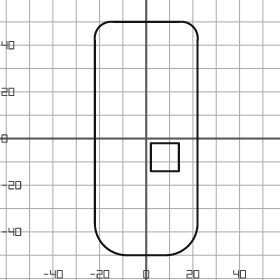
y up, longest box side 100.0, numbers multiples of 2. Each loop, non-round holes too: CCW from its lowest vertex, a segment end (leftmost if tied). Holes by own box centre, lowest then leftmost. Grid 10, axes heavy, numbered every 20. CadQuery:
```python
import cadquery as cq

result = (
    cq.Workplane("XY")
    .moveTo(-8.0, -50.0)
    .lineTo(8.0, -50.0)
    .threePointArc((18.0, -46.0), (22.0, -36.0))
    .lineTo(22.0, 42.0)
    .threePointArc((20.0, 48.0), (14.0, 50.0))
    .lineTo(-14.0, 50.0)
    .threePointArc((-20.0, 48.0), (-22.0, 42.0))
    .lineTo(-22.0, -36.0)
    .threePointArc((-18.0, -46.0), (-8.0, -50.0))
    .close()
    .moveTo(2.0, -14.0)
    .lineTo(14.0, -14.0)
    .lineTo(14.0, -2.0)
    .lineTo(2.0, -2.0)
    .close()
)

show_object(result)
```